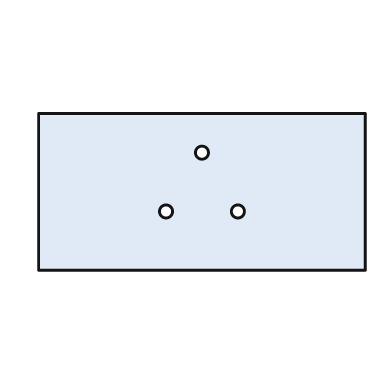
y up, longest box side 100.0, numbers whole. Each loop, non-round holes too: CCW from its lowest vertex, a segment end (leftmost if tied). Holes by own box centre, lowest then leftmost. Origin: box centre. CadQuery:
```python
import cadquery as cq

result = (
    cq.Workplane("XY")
    .moveTo(-50.0, -24.0)
    .lineTo(50.0, -24.0)
    .lineTo(50.0, 24.0)
    .lineTo(-50.0, 24.0)
    .close()
    .moveTo(-11.0, -6.0)
    .circle(2.0)
    .moveTo(11.0, -6.0)
    .circle(2.0)
    .moveTo(0.0, 12.0)
    .circle(2.0)
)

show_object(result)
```